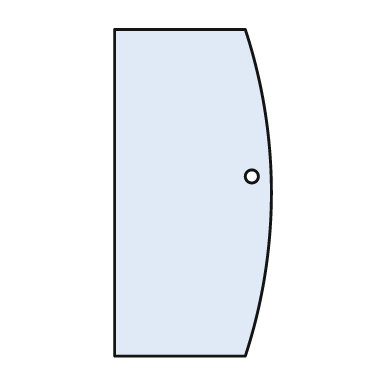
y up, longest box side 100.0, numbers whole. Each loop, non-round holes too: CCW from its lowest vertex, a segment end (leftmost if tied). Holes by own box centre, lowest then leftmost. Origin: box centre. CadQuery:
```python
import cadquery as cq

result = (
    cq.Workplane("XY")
    .moveTo(-24.0, -50.0)
    .lineTo(16.0, -50.0)
    .threePointArc((24.0, 0.0), (16.0, 50.0))
    .lineTo(-24.0, 50.0)
    .close()
    .moveTo(18.0, 5.0)
    .circle(2.0)
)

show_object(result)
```